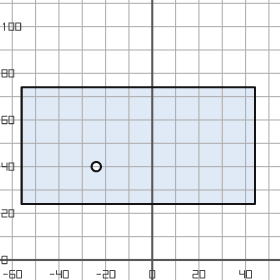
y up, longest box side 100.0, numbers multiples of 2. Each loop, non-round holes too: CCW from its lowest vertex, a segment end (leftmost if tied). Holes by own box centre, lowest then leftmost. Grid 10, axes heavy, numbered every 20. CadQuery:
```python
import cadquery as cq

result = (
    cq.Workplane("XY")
    .moveTo(-56.0, 24.0)
    .lineTo(44.0, 24.0)
    .lineTo(44.0, 74.0)
    .lineTo(-56.0, 74.0)
    .close()
    .moveTo(-24.0, 40.0)
    .circle(2.0)
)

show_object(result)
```